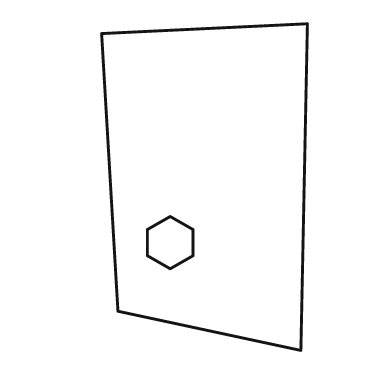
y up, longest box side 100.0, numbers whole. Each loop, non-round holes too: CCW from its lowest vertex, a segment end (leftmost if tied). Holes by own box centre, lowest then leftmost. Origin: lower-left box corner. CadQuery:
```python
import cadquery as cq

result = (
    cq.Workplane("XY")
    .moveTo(61.0, 0.0)
    .lineTo(63.0, 100.0)
    .lineTo(0.0, 97.0)
    .lineTo(5.0, 12.0)
    .close()
    .moveTo(21.0, 25.0)
    .lineTo(28.0, 29.0)
    .lineTo(28.0, 37.0)
    .lineTo(21.0, 41.0)
    .lineTo(14.0, 37.0)
    .lineTo(14.0, 29.0)
    .close()
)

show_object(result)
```